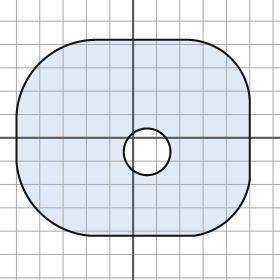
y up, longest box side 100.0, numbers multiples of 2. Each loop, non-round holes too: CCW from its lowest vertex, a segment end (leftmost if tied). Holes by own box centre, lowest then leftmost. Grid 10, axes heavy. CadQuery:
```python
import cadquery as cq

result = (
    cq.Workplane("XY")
    .moveTo(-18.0, -42.0)
    .lineTo(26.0, -42.0)
    .threePointArc((42.0, -34.0), (50.0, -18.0))
    .lineTo(50.0, 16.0)
    .threePointArc((42.0, 34.0), (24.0, 42.0))
    .lineTo(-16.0, 42.0)
    .threePointArc((-40.0, 32.0), (-50.0, 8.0))
    .lineTo(-50.0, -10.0)
    .threePointArc((-40.0, -32.0), (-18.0, -42.0))
    .close()
    .moveTo(6.0, -6.0)
    .circle(10.0)
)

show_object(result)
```